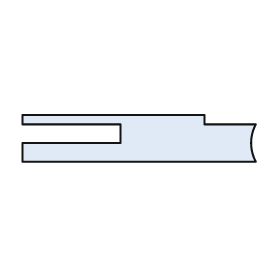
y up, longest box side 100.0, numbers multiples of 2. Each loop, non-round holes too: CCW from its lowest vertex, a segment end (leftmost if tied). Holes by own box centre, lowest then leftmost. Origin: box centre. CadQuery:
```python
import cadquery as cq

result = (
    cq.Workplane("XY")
    .moveTo(-50.0, -10.0)
    .lineTo(50.0, -10.0)
    .threePointArc((48.0, -2.0), (50.0, 6.0))
    .lineTo(28.0, 6.0)
    .lineTo(28.0, 10.0)
    .lineTo(-50.0, 10.0)
    .lineTo(-50.0, 6.0)
    .lineTo(-8.0, 6.0)
    .lineTo(-8.0, -2.0)
    .lineTo(-50.0, -2.0)
    .close()
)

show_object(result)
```